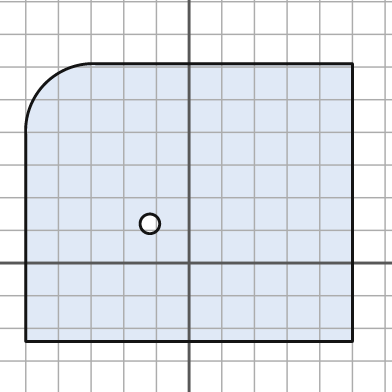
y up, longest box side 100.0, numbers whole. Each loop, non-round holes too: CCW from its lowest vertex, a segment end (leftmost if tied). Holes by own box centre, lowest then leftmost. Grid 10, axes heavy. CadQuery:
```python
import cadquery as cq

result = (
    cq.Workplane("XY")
    .moveTo(-50.0, -24.0)
    .lineTo(50.0, -24.0)
    .lineTo(50.0, 61.0)
    .lineTo(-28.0, 61.0)
    .threePointArc((-44.0, 55.0), (-50.0, 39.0))
    .close()
    .moveTo(-12.0, 12.0)
    .circle(3.0)
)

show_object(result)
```